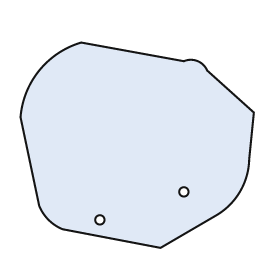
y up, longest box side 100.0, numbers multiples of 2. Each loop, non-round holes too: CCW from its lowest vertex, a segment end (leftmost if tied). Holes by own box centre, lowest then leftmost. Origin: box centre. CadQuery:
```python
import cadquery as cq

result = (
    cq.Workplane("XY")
    .moveTo(10.0, -44.0)
    .lineTo(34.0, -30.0)
    .threePointArc((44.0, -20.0), (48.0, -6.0))
    .lineTo(50.0, 14.0)
    .lineTo(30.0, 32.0)
    .threePointArc((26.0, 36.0), (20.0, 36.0))
    .lineTo(-24.0, 44.0)
    .threePointArc((-42.0, 32.0), (-50.0, 12.0))
    .lineTo(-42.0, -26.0)
    .threePointArc((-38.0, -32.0), (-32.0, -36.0))
    .close()
    .moveTo(-16.0, -32.0)
    .circle(2.0)
    .moveTo(20.0, -20.0)
    .circle(2.0)
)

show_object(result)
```